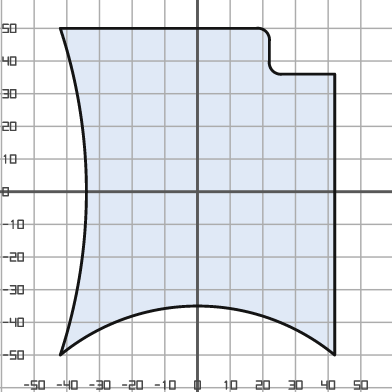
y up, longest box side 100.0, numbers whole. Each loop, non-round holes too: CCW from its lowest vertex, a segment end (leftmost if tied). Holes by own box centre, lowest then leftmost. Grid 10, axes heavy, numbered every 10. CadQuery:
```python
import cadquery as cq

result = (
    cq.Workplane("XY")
    .moveTo(-42.0, -50.0)
    .threePointArc((0.0, -35.0), (42.0, -50.0))
    .lineTo(42.0, 36.0)
    .lineTo(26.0, 36.0)
    .threePointArc((23.0, 37.0), (22.0, 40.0))
    .lineTo(22.0, 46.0)
    .threePointArc((21.0, 49.0), (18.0, 50.0))
    .lineTo(-42.0, 50.0)
    .threePointArc((-34.0, 0.0), (-42.0, -50.0))
    .close()
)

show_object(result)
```